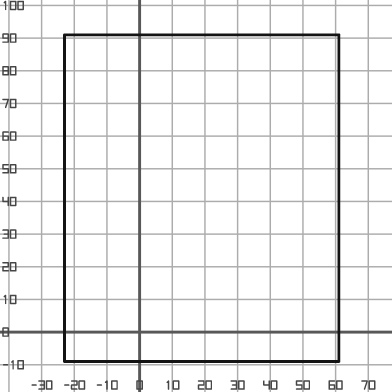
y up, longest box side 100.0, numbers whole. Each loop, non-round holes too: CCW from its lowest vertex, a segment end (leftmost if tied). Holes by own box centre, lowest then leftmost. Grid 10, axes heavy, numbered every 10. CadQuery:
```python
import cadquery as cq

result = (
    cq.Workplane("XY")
    .moveTo(-23.0, -9.0)
    .lineTo(61.0, -9.0)
    .lineTo(61.0, 91.0)
    .lineTo(-23.0, 91.0)
    .close()
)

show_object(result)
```